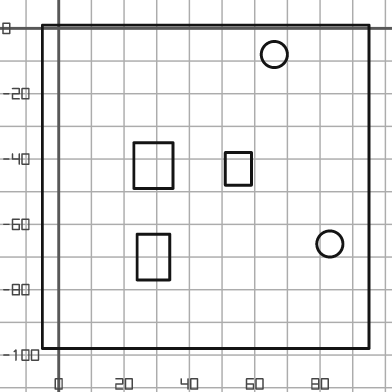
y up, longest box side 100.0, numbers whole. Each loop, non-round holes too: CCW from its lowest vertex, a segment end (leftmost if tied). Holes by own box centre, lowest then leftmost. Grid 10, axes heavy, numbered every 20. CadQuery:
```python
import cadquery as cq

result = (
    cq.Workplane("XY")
    .moveTo(-5.0, -98.0)
    .lineTo(95.0, -98.0)
    .lineTo(95.0, 1.0)
    .lineTo(-5.0, 1.0)
    .close()
    .moveTo(24.0, -77.0)
    .lineTo(34.0, -77.0)
    .lineTo(34.0, -63.0)
    .lineTo(24.0, -63.0)
    .close()
    .moveTo(83.0, -66.0)
    .circle(4.0)
    .moveTo(51.0, -48.0)
    .lineTo(59.0, -48.0)
    .lineTo(59.0, -38.0)
    .lineTo(51.0, -38.0)
    .close()
    .moveTo(23.0, -49.0)
    .lineTo(35.0, -49.0)
    .lineTo(35.0, -35.0)
    .lineTo(23.0, -35.0)
    .close()
    .moveTo(66.0, -8.0)
    .circle(4.0)
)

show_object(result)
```